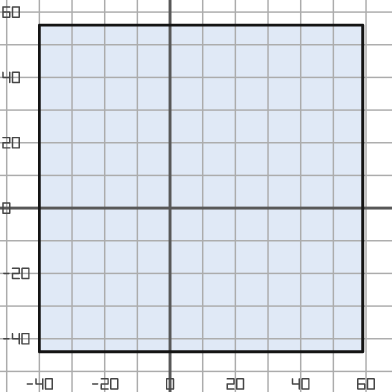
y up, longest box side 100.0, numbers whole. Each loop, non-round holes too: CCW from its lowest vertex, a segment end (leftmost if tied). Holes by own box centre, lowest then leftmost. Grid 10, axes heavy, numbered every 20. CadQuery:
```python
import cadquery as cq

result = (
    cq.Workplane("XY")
    .moveTo(-40.0, -44.0)
    .lineTo(59.0, -44.0)
    .lineTo(59.0, 56.0)
    .lineTo(-40.0, 56.0)
    .close()
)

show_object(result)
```